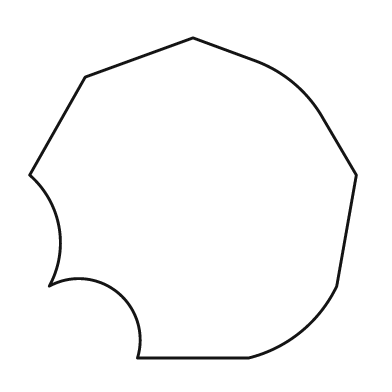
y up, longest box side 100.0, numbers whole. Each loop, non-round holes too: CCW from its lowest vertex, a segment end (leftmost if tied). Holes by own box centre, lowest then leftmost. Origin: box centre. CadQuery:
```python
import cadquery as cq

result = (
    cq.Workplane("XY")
    .moveTo(-17.0, -49.0)
    .lineTo(17.0, -49.0)
    .threePointArc((33.0, -41.0), (44.0, -27.0))
    .lineTo(50.0, 7.0)
    .lineTo(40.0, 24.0)
    .threePointArc((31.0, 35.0), (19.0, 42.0))
    .lineTo(0.0, 49.0)
    .lineTo(-33.0, 37.0)
    .lineTo(-50.0, 7.0)
    .threePointArc((-41.0, -9.0), (-44.0, -27.0))
    .threePointArc((-23.0, -29.0), (-17.0, -49.0))
    .close()
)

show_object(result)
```